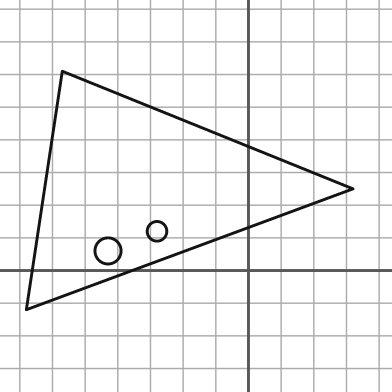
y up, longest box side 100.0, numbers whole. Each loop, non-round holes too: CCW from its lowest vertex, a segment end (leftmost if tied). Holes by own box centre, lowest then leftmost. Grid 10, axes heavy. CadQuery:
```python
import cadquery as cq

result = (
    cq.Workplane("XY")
    .moveTo(-68.0, -12.0)
    .lineTo(32.0, 25.0)
    .lineTo(-57.0, 61.0)
    .close()
    .moveTo(-43.0, 6.0)
    .circle(4.0)
    .moveTo(-28.0, 12.0)
    .circle(3.0)
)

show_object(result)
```